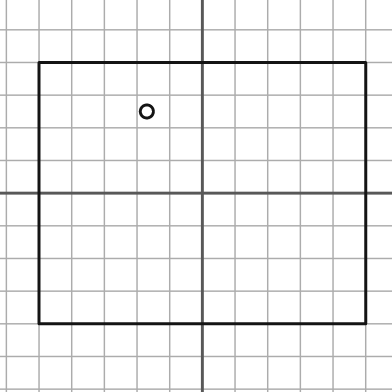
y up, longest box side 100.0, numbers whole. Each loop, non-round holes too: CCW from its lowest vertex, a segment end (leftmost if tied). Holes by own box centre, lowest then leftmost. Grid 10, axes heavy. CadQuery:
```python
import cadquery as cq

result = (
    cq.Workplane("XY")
    .moveTo(-50.0, -40.0)
    .lineTo(50.0, -40.0)
    .lineTo(50.0, 40.0)
    .lineTo(-50.0, 40.0)
    .close()
    .moveTo(-17.0, 25.0)
    .circle(2.0)
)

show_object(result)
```